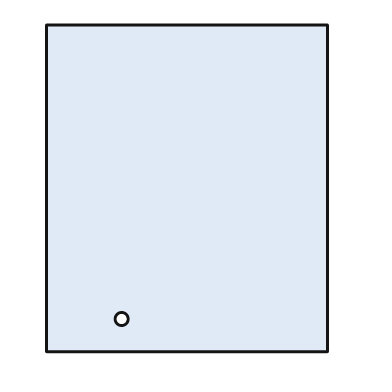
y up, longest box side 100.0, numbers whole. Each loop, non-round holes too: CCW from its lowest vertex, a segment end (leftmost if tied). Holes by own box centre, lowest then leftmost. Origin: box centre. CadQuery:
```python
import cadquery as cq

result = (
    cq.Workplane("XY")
    .moveTo(-43.0, -50.0)
    .lineTo(43.0, -50.0)
    .lineTo(43.0, 50.0)
    .lineTo(-43.0, 50.0)
    .close()
    .moveTo(-20.0, -40.0)
    .circle(2.0)
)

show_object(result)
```